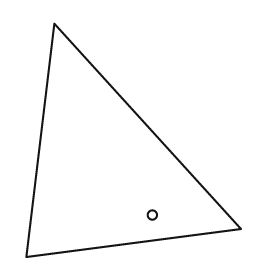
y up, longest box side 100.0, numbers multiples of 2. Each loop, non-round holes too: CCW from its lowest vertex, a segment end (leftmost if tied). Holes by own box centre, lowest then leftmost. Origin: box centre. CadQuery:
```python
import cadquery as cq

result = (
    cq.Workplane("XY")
    .moveTo(-46.0, -50.0)
    .lineTo(46.0, -38.0)
    .lineTo(-34.0, 50.0)
    .close()
    .moveTo(8.0, -32.0)
    .circle(2.0)
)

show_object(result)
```